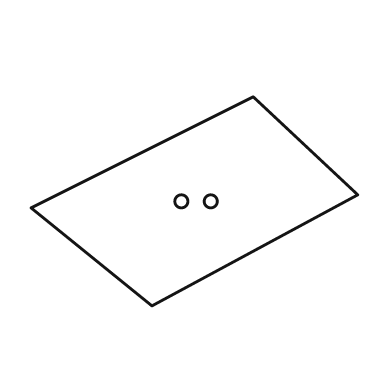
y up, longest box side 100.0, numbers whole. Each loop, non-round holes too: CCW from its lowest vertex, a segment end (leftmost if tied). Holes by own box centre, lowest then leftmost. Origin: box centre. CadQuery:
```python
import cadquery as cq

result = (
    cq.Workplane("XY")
    .moveTo(-13.0, -32.0)
    .lineTo(50.0, 2.0)
    .lineTo(18.0, 32.0)
    .lineTo(-50.0, -2.0)
    .close()
    .moveTo(-4.0, 0.0)
    .circle(2.0)
    .moveTo(5.0, 0.0)
    .circle(2.0)
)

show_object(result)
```